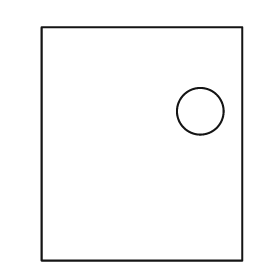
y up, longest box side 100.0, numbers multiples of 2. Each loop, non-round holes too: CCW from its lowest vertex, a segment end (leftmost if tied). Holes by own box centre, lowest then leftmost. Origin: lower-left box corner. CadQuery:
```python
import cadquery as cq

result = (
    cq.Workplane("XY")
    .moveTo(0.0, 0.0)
    .lineTo(86.0, 0.0)
    .lineTo(86.0, 100.0)
    .lineTo(0.0, 100.0)
    .close()
    .moveTo(68.0, 64.0)
    .circle(10.0)
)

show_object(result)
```